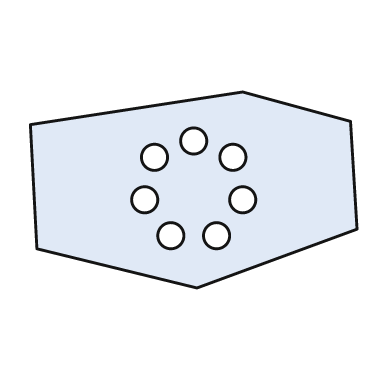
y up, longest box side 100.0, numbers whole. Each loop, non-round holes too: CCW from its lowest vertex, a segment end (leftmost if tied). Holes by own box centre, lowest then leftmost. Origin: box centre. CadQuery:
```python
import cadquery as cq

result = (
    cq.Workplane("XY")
    .moveTo(1.0, -30.0)
    .lineTo(50.0, -12.0)
    .lineTo(48.0, 21.0)
    .lineTo(15.0, 30.0)
    .lineTo(-50.0, 20.0)
    .lineTo(-48.0, -18.0)
    .close()
    .moveTo(-7.0, -14.0)
    .circle(4.0)
    .moveTo(7.0, -14.0)
    .circle(4.0)
    .moveTo(-15.0, -3.0)
    .circle(4.0)
    .moveTo(15.0, -3.0)
    .circle(4.0)
    .moveTo(-12.0, 10.0)
    .circle(4.0)
    .moveTo(12.0, 10.0)
    .circle(4.0)
    .moveTo(0.0, 15.0)
    .circle(4.0)
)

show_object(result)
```